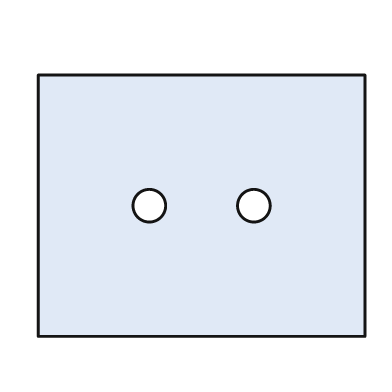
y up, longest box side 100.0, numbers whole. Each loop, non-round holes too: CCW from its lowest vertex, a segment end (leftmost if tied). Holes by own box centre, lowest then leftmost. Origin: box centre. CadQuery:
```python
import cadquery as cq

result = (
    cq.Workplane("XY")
    .moveTo(-50.0, -40.0)
    .lineTo(50.0, -40.0)
    .lineTo(50.0, 40.0)
    .lineTo(-50.0, 40.0)
    .close()
    .moveTo(-16.0, 0.0)
    .circle(5.0)
    .moveTo(16.0, 0.0)
    .circle(5.0)
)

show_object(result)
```